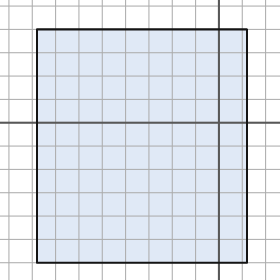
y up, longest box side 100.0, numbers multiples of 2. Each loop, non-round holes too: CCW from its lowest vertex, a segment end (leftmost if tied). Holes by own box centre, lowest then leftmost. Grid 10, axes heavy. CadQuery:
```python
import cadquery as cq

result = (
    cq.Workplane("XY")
    .moveTo(-78.0, -60.0)
    .lineTo(12.0, -60.0)
    .lineTo(12.0, 40.0)
    .lineTo(-78.0, 40.0)
    .close()
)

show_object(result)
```